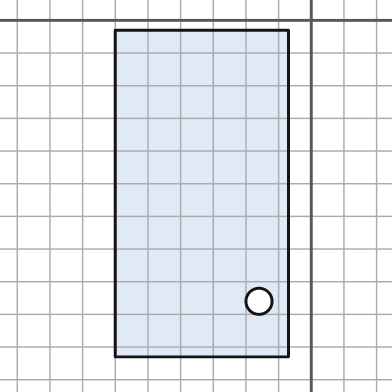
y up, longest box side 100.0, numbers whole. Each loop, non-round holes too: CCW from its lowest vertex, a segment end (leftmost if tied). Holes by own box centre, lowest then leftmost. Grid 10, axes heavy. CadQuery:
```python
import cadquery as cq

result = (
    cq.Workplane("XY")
    .moveTo(-60.0, -103.0)
    .lineTo(-7.0, -103.0)
    .lineTo(-7.0, -3.0)
    .lineTo(-60.0, -3.0)
    .close()
    .moveTo(-16.0, -86.0)
    .circle(4.0)
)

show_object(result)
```